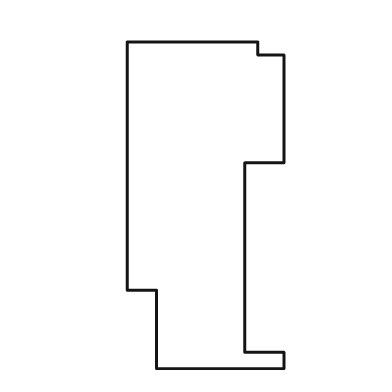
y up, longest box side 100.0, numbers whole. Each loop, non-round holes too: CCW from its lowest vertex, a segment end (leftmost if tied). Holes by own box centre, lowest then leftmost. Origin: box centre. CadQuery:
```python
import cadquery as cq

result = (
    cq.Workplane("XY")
    .moveTo(-15.0, -50.0)
    .lineTo(24.0, -50.0)
    .lineTo(24.0, -45.0)
    .lineTo(12.0, -45.0)
    .lineTo(12.0, 13.0)
    .lineTo(24.0, 13.0)
    .lineTo(24.0, 46.0)
    .lineTo(16.0, 46.0)
    .lineTo(16.0, 50.0)
    .lineTo(-24.0, 50.0)
    .lineTo(-24.0, -26.0)
    .lineTo(-15.0, -26.0)
    .close()
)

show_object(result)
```